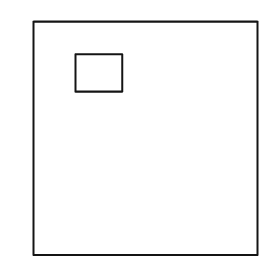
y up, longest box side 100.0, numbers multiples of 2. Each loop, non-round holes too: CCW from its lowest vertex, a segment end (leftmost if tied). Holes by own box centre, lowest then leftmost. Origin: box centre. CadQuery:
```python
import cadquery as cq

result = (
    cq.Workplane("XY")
    .moveTo(-48.0, -50.0)
    .lineTo(48.0, -50.0)
    .lineTo(48.0, 50.0)
    .lineTo(-48.0, 50.0)
    .close()
    .moveTo(-30.0, 20.0)
    .lineTo(-10.0, 20.0)
    .lineTo(-10.0, 36.0)
    .lineTo(-30.0, 36.0)
    .close()
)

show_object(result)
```